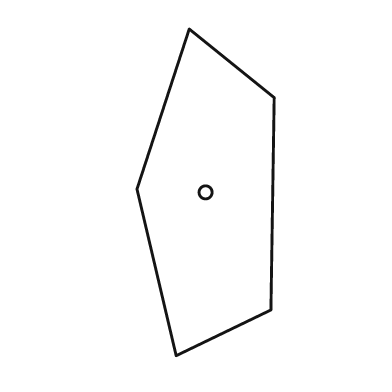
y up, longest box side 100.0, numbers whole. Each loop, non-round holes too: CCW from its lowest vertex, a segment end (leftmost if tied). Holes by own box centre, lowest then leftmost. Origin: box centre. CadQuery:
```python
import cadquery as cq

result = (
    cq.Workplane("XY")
    .moveTo(-9.0, -50.0)
    .lineTo(20.0, -36.0)
    .lineTo(21.0, 29.0)
    .lineTo(-5.0, 50.0)
    .lineTo(-21.0, 1.0)
    .close()
    .moveTo(0.0, 0.0)
    .circle(2.0)
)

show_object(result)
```